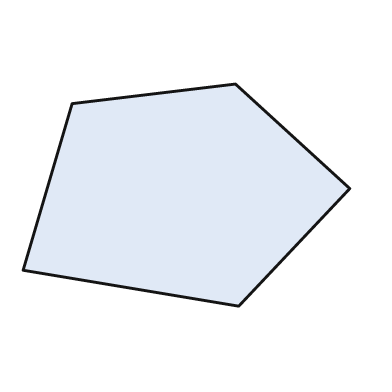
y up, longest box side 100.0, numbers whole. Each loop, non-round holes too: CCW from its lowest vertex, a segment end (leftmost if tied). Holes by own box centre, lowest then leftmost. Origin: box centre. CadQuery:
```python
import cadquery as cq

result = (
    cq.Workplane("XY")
    .moveTo(16.0, -34.0)
    .lineTo(50.0, 2.0)
    .lineTo(15.0, 34.0)
    .lineTo(-35.0, 28.0)
    .lineTo(-50.0, -23.0)
    .close()
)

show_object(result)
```